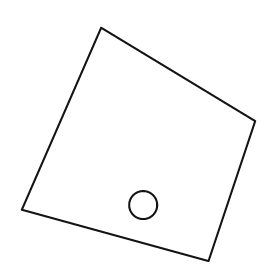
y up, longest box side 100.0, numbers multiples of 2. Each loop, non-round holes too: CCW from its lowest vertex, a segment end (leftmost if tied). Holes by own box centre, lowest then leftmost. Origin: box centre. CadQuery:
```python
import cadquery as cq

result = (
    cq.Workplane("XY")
    .moveTo(30.0, -50.0)
    .lineTo(50.0, 10.0)
    .lineTo(-16.0, 50.0)
    .lineTo(-50.0, -28.0)
    .close()
    .moveTo(2.0, -26.0)
    .circle(6.0)
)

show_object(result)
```